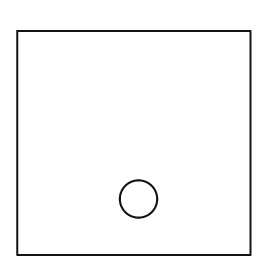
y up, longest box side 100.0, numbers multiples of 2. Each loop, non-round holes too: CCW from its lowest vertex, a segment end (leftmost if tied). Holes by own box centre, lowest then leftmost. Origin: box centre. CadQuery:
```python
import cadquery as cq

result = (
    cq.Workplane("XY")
    .moveTo(-50.0, -48.0)
    .lineTo(50.0, -48.0)
    .lineTo(50.0, 48.0)
    .lineTo(-50.0, 48.0)
    .close()
    .moveTo(2.0, -24.0)
    .circle(8.0)
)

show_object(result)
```